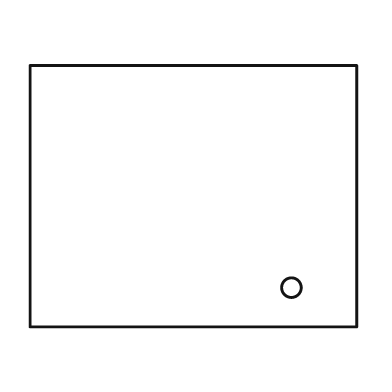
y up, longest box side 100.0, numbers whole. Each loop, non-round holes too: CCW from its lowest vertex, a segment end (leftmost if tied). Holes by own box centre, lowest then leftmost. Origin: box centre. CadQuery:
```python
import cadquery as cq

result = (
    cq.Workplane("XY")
    .moveTo(-50.0, -40.0)
    .lineTo(50.0, -40.0)
    .lineTo(50.0, 40.0)
    .lineTo(-50.0, 40.0)
    .close()
    .moveTo(30.0, -28.0)
    .circle(3.0)
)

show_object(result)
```